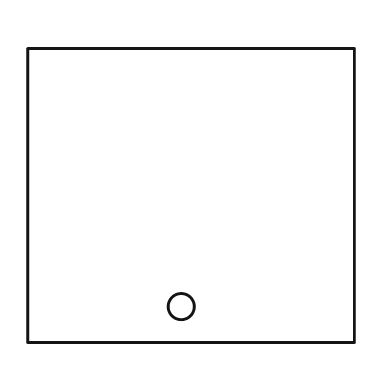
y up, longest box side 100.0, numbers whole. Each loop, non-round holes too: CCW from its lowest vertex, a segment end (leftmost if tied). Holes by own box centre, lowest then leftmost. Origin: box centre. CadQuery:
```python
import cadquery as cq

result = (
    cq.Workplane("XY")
    .moveTo(-50.0, -45.0)
    .lineTo(50.0, -45.0)
    .lineTo(50.0, 45.0)
    .lineTo(-50.0, 45.0)
    .close()
    .moveTo(-3.0, -34.0)
    .circle(4.0)
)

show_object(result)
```